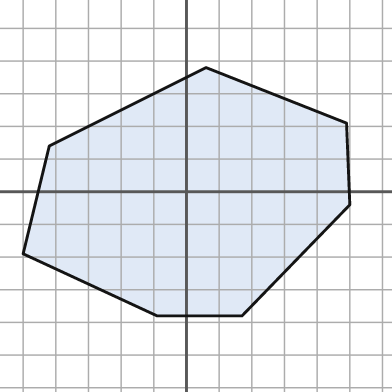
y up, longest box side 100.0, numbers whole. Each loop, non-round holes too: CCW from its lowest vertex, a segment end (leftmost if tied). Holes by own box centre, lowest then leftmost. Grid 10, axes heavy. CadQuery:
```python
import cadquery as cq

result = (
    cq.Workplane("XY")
    .moveTo(-9.0, -38.0)
    .lineTo(17.0, -38.0)
    .lineTo(50.0, -4.0)
    .lineTo(49.0, 21.0)
    .lineTo(6.0, 38.0)
    .lineTo(-42.0, 14.0)
    .lineTo(-50.0, -19.0)
    .close()
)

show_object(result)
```